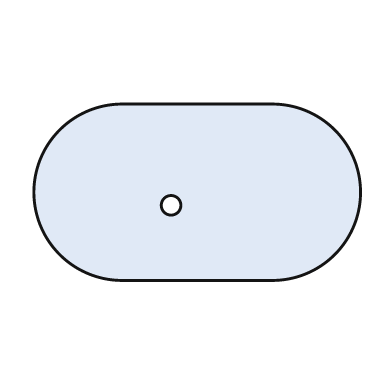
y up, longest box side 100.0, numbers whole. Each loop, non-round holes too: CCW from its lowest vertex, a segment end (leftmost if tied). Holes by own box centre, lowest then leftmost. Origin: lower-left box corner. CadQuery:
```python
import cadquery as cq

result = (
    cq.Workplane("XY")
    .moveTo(27.0, 0.0)
    .lineTo(73.0, 0.0)
    .threePointArc((100.0, 27.0), (73.0, 54.0))
    .lineTo(27.0, 54.0)
    .threePointArc((0.0, 27.0), (27.0, 0.0))
    .close()
    .moveTo(42.0, 23.0)
    .circle(3.0)
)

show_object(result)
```